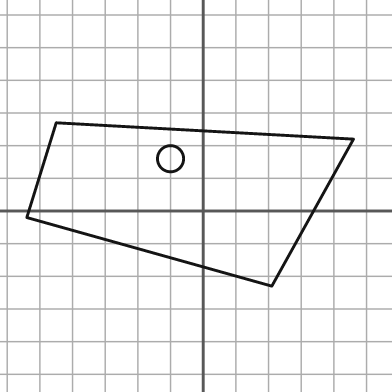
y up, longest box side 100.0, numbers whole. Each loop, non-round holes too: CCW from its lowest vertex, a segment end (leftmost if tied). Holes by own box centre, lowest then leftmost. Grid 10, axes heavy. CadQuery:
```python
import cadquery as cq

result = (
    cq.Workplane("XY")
    .moveTo(21.0, -23.0)
    .lineTo(46.0, 22.0)
    .lineTo(-45.0, 27.0)
    .lineTo(-54.0, -2.0)
    .close()
    .moveTo(-10.0, 16.0)
    .circle(4.0)
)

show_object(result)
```